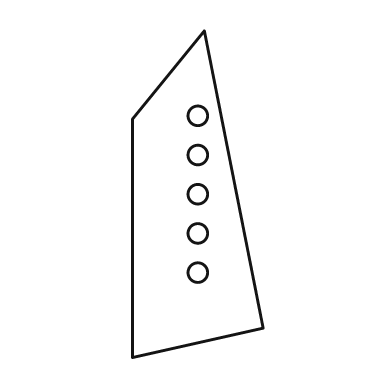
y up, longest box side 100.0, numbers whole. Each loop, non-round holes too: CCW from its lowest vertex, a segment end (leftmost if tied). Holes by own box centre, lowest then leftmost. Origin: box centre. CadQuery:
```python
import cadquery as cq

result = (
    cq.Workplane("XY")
    .moveTo(-20.0, -50.0)
    .lineTo(20.0, -41.0)
    .lineTo(2.0, 50.0)
    .lineTo(-20.0, 23.0)
    .close()
    .moveTo(0.0, -24.0)
    .circle(3.0)
    .moveTo(0.0, -12.0)
    .circle(3.0)
    .moveTo(0.0, 0.0)
    .circle(3.0)
    .moveTo(0.0, 12.0)
    .circle(3.0)
    .moveTo(0.0, 24.0)
    .circle(3.0)
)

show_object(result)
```